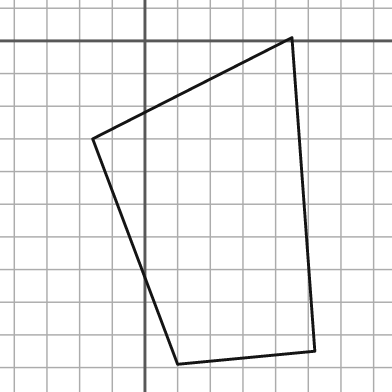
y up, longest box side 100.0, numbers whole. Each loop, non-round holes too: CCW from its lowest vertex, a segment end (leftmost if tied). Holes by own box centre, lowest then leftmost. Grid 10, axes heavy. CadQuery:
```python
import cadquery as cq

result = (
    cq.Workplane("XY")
    .moveTo(10.0, -99.0)
    .lineTo(52.0, -95.0)
    .lineTo(45.0, 1.0)
    .lineTo(-16.0, -30.0)
    .close()
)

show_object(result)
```